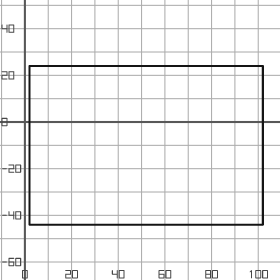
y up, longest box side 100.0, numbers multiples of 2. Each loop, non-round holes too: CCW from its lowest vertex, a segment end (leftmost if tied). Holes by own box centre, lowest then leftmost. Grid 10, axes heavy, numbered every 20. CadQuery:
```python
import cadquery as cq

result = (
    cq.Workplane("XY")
    .moveTo(2.0, -44.0)
    .lineTo(102.0, -44.0)
    .lineTo(102.0, 24.0)
    .lineTo(2.0, 24.0)
    .close()
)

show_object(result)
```